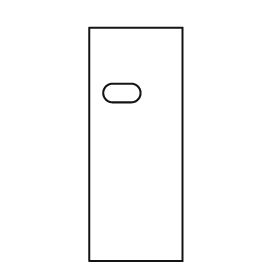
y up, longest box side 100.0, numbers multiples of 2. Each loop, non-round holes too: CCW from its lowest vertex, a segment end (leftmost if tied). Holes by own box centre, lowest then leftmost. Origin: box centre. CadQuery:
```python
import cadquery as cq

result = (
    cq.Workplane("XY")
    .moveTo(-20.0, -50.0)
    .lineTo(20.0, -50.0)
    .lineTo(20.0, 50.0)
    .lineTo(-20.0, 50.0)
    .close()
    .moveTo(-10.0, 18.0)
    .lineTo(-2.0, 18.0)
    .threePointArc((2.0, 22.0), (-2.0, 26.0))
    .lineTo(-10.0, 26.0)
    .threePointArc((-14.0, 22.0), (-10.0, 18.0))
    .close()
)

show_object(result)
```